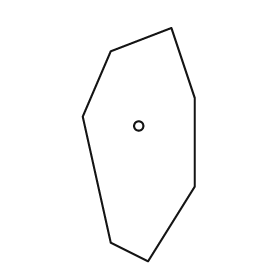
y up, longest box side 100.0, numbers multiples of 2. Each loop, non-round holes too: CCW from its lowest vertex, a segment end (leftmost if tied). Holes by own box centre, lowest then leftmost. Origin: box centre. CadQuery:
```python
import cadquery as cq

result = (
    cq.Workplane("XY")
    .moveTo(4.0, -50.0)
    .lineTo(24.0, -18.0)
    .lineTo(24.0, 20.0)
    .lineTo(14.0, 50.0)
    .lineTo(-12.0, 40.0)
    .lineTo(-24.0, 12.0)
    .lineTo(-12.0, -42.0)
    .close()
    .moveTo(0.0, 8.0)
    .circle(2.0)
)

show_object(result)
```